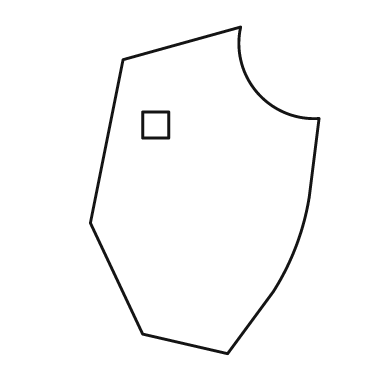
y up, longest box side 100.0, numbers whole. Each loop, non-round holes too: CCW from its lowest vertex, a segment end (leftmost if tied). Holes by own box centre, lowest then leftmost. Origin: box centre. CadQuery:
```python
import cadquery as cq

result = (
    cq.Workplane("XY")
    .moveTo(7.0, -50.0)
    .lineTo(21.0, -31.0)
    .threePointArc((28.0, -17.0), (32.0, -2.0))
    .lineTo(35.0, 22.0)
    .threePointArc((16.0, 30.0), (11.0, 50.0))
    .lineTo(-25.0, 40.0)
    .lineTo(-35.0, -10.0)
    .lineTo(-19.0, -44.0)
    .close()
    .moveTo(-19.0, 16.0)
    .lineTo(-11.0, 16.0)
    .lineTo(-11.0, 24.0)
    .lineTo(-19.0, 24.0)
    .close()
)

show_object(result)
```